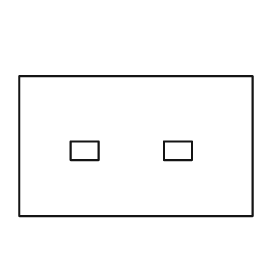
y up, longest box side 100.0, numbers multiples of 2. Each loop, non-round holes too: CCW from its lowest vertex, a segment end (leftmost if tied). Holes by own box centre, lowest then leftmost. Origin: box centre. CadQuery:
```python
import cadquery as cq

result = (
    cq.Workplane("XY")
    .moveTo(-50.0, -30.0)
    .lineTo(50.0, -30.0)
    .lineTo(50.0, 30.0)
    .lineTo(-50.0, 30.0)
    .close()
    .moveTo(-28.0, -6.0)
    .lineTo(-16.0, -6.0)
    .lineTo(-16.0, 2.0)
    .lineTo(-28.0, 2.0)
    .close()
    .moveTo(12.0, -6.0)
    .lineTo(24.0, -6.0)
    .lineTo(24.0, 2.0)
    .lineTo(12.0, 2.0)
    .close()
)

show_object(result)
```